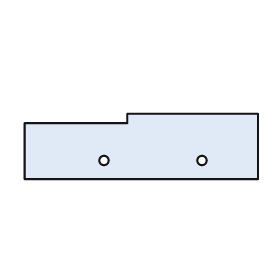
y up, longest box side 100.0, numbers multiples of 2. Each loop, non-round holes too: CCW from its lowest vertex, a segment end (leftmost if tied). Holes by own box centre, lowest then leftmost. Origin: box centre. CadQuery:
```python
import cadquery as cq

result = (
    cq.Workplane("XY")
    .moveTo(-50.0, -14.0)
    .lineTo(50.0, -14.0)
    .lineTo(50.0, 14.0)
    .lineTo(-6.0, 14.0)
    .lineTo(-6.0, 10.0)
    .lineTo(-50.0, 10.0)
    .close()
    .moveTo(-16.0, -6.0)
    .circle(2.0)
    .moveTo(26.0, -6.0)
    .circle(2.0)
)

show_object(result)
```